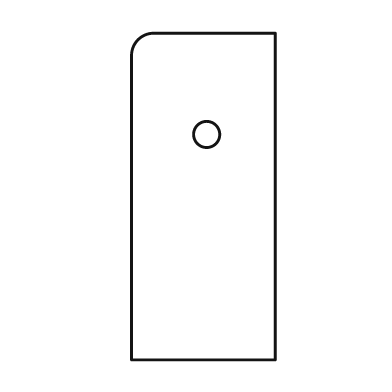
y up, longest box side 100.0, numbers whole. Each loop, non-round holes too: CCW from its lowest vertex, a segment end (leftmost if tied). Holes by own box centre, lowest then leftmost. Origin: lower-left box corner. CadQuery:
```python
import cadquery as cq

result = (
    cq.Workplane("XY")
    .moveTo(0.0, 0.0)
    .lineTo(44.0, 0.0)
    .lineTo(44.0, 100.0)
    .lineTo(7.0, 100.0)
    .threePointArc((2.0, 98.0), (0.0, 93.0))
    .close()
    .moveTo(23.0, 69.0)
    .circle(4.0)
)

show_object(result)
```